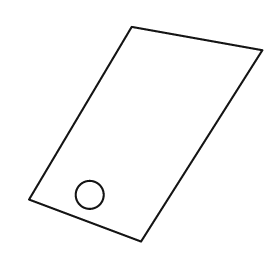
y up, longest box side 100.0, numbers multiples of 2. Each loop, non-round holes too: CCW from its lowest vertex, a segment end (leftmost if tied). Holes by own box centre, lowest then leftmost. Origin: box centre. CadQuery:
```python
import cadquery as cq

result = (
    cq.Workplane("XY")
    .moveTo(-2.0, -46.0)
    .lineTo(50.0, 36.0)
    .lineTo(-6.0, 46.0)
    .lineTo(-50.0, -28.0)
    .close()
    .moveTo(-24.0, -26.0)
    .circle(6.0)
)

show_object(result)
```